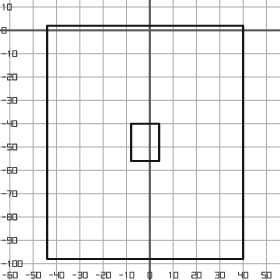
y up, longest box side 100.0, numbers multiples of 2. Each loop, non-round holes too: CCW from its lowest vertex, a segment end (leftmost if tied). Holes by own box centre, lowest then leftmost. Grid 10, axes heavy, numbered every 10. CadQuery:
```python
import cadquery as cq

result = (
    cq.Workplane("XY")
    .moveTo(-44.0, -98.0)
    .lineTo(40.0, -98.0)
    .lineTo(40.0, 2.0)
    .lineTo(-44.0, 2.0)
    .close()
    .moveTo(-8.0, -56.0)
    .lineTo(4.0, -56.0)
    .lineTo(4.0, -40.0)
    .lineTo(-8.0, -40.0)
    .close()
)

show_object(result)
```